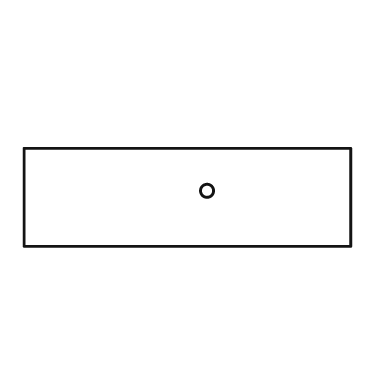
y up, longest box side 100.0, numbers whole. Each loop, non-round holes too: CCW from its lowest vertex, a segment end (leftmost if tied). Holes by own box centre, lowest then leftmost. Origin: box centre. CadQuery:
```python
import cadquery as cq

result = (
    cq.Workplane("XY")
    .moveTo(-50.0, -15.0)
    .lineTo(50.0, -15.0)
    .lineTo(50.0, 15.0)
    .lineTo(-50.0, 15.0)
    .close()
    .moveTo(6.0, 2.0)
    .circle(2.0)
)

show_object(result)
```